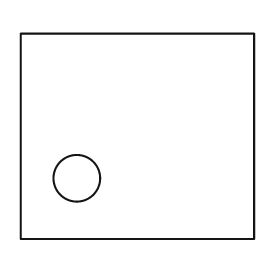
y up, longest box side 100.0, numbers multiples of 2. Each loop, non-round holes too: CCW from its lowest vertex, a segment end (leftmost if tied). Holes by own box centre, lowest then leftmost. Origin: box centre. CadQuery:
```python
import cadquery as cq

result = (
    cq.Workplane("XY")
    .moveTo(-50.0, -44.0)
    .lineTo(50.0, -44.0)
    .lineTo(50.0, 44.0)
    .lineTo(-50.0, 44.0)
    .close()
    .moveTo(-26.0, -18.0)
    .circle(10.0)
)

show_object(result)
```